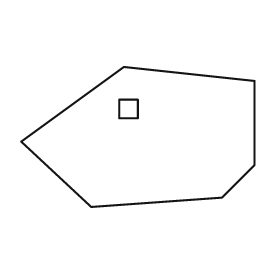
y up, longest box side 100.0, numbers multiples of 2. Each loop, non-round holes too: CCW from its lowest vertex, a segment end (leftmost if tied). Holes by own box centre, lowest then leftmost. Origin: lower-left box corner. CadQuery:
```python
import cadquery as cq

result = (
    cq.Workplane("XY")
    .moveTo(30.0, 0.0)
    .lineTo(86.0, 4.0)
    .lineTo(100.0, 18.0)
    .lineTo(100.0, 54.0)
    .lineTo(44.0, 60.0)
    .lineTo(0.0, 28.0)
    .close()
    .moveTo(42.0, 38.0)
    .lineTo(50.0, 38.0)
    .lineTo(50.0, 46.0)
    .lineTo(42.0, 46.0)
    .close()
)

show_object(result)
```